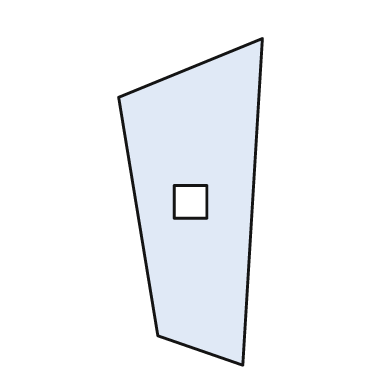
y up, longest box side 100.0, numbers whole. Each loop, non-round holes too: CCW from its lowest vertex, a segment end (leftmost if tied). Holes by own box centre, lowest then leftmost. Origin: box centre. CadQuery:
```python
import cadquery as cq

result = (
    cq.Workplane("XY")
    .moveTo(16.0, -50.0)
    .lineTo(22.0, 50.0)
    .lineTo(-22.0, 32.0)
    .lineTo(-10.0, -41.0)
    .close()
    .moveTo(-5.0, -5.0)
    .lineTo(5.0, -5.0)
    .lineTo(5.0, 5.0)
    .lineTo(-5.0, 5.0)
    .close()
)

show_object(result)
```